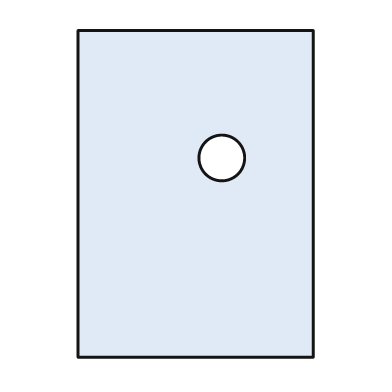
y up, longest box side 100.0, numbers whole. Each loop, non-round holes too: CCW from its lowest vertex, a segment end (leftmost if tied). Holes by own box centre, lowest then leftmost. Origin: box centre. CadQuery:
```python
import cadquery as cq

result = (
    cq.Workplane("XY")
    .moveTo(-36.0, -50.0)
    .lineTo(36.0, -50.0)
    .lineTo(36.0, 50.0)
    .lineTo(-36.0, 50.0)
    .close()
    .moveTo(8.0, 11.0)
    .circle(7.0)
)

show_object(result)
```